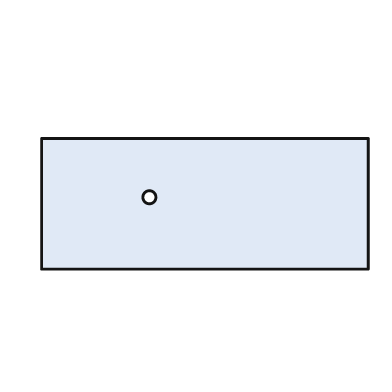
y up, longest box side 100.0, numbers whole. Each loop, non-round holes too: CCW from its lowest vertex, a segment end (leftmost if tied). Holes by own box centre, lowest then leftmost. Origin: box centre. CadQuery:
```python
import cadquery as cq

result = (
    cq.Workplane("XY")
    .moveTo(-50.0, -20.0)
    .lineTo(50.0, -20.0)
    .lineTo(50.0, 20.0)
    .lineTo(-50.0, 20.0)
    .close()
    .moveTo(-17.0, 2.0)
    .circle(2.0)
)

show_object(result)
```